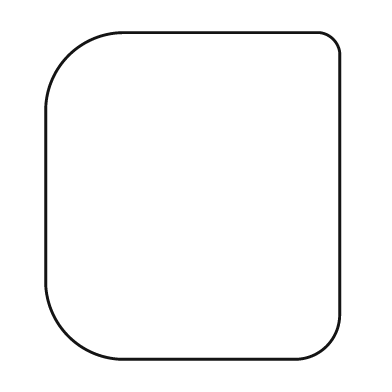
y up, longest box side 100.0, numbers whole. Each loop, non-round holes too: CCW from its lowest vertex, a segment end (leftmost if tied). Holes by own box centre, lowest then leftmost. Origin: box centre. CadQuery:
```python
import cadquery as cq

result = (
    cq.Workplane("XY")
    .moveTo(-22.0, -50.0)
    .lineTo(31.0, -50.0)
    .threePointArc((41.0, -46.0), (45.0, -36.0))
    .lineTo(45.0, 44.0)
    .threePointArc((43.0, 48.0), (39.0, 50.0))
    .lineTo(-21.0, 50.0)
    .threePointArc((-38.0, 43.0), (-45.0, 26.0))
    .lineTo(-45.0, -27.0)
    .threePointArc((-38.0, -43.0), (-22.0, -50.0))
    .close()
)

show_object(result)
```